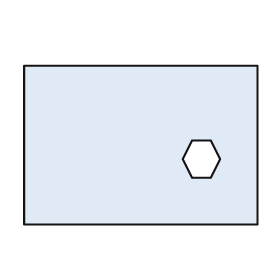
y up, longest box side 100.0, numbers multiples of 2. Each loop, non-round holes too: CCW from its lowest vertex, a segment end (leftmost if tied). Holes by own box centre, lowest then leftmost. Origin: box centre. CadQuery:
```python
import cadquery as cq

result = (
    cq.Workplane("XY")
    .moveTo(-50.0, -34.0)
    .lineTo(50.0, -34.0)
    .lineTo(50.0, 34.0)
    .lineTo(-50.0, 34.0)
    .close()
    .moveTo(22.0, -14.0)
    .lineTo(30.0, -14.0)
    .lineTo(34.0, -6.0)
    .lineTo(30.0, 2.0)
    .lineTo(22.0, 2.0)
    .lineTo(18.0, -6.0)
    .close()
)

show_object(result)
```